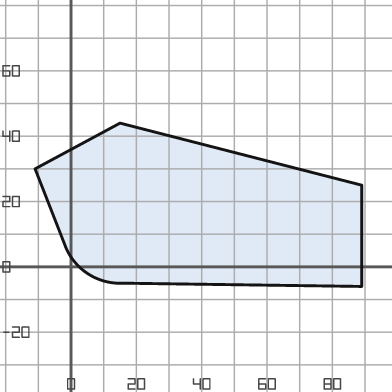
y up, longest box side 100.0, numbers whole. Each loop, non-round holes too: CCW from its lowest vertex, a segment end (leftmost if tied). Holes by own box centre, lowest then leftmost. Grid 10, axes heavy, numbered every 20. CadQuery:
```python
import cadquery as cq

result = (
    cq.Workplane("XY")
    .moveTo(89.0, -6.0)
    .lineTo(89.0, 25.0)
    .lineTo(15.0, 44.0)
    .lineTo(-11.0, 30.0)
    .lineTo(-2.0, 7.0)
    .threePointArc((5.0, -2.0), (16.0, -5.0))
    .close()
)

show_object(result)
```